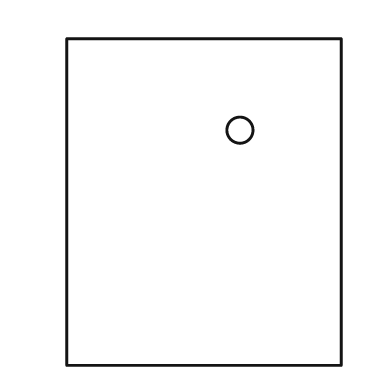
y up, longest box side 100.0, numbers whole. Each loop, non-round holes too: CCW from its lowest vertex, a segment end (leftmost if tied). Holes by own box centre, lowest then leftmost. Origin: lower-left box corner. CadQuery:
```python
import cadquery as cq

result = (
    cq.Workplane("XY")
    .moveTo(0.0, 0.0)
    .lineTo(84.0, 0.0)
    .lineTo(84.0, 100.0)
    .lineTo(0.0, 100.0)
    .close()
    .moveTo(53.0, 72.0)
    .circle(4.0)
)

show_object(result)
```